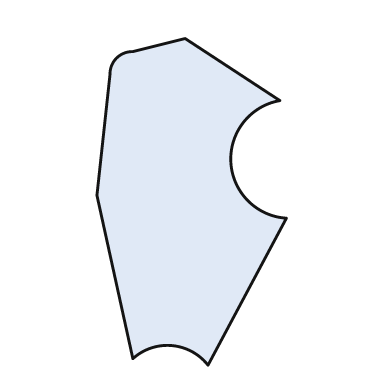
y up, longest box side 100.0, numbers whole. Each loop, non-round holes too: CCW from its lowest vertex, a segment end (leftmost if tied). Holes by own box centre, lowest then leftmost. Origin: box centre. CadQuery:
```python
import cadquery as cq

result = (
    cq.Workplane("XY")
    .moveTo(5.0, -50.0)
    .lineTo(29.0, -5.0)
    .threePointArc((12.0, 12.0), (27.0, 31.0))
    .lineTo(-2.0, 50.0)
    .lineTo(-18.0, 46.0)
    .threePointArc((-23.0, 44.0), (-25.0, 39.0))
    .lineTo(-29.0, 2.0)
    .lineTo(-18.0, -48.0)
    .threePointArc((-6.0, -44.0), (5.0, -50.0))
    .close()
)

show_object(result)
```